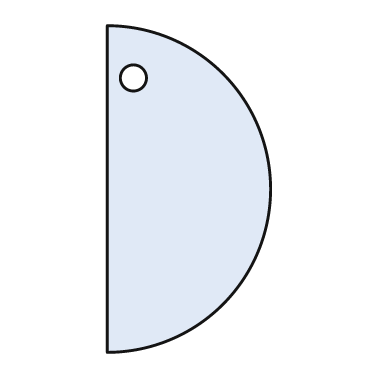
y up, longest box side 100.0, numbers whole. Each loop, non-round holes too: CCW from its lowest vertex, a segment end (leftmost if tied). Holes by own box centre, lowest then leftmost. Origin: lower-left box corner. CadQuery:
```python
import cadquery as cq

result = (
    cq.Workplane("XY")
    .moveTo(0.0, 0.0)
    .threePointArc((50.0, 50.0), (0.0, 100.0))
    .close()
    .moveTo(8.0, 84.0)
    .circle(4.0)
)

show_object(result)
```